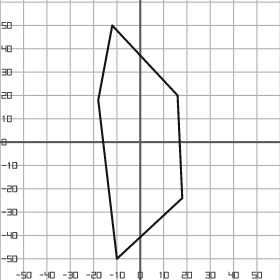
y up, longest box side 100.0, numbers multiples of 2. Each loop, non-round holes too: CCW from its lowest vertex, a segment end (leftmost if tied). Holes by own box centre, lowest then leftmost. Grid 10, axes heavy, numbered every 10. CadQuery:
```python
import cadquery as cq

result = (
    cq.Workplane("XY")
    .moveTo(-10.0, -50.0)
    .lineTo(18.0, -24.0)
    .lineTo(16.0, 20.0)
    .lineTo(-12.0, 50.0)
    .lineTo(-18.0, 18.0)
    .close()
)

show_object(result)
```